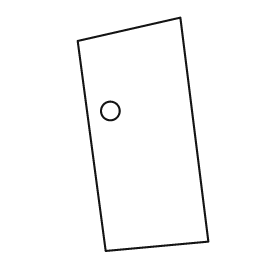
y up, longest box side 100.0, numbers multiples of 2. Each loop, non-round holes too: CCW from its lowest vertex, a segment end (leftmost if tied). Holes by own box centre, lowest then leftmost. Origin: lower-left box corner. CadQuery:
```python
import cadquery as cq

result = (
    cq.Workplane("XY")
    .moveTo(12.0, 0.0)
    .lineTo(56.0, 4.0)
    .lineTo(44.0, 100.0)
    .lineTo(0.0, 90.0)
    .close()
    .moveTo(14.0, 60.0)
    .circle(4.0)
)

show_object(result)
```